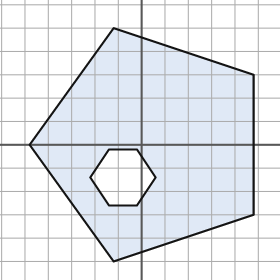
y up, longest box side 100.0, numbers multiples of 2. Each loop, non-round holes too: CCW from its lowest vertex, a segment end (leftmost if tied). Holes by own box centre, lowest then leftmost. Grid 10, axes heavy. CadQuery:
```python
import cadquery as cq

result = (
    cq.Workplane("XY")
    .moveTo(-12.0, -50.0)
    .lineTo(48.0, -30.0)
    .lineTo(48.0, 30.0)
    .lineTo(-12.0, 50.0)
    .lineTo(-48.0, 0.0)
    .close()
    .moveTo(-14.0, -26.0)
    .lineTo(-2.0, -26.0)
    .lineTo(6.0, -14.0)
    .lineTo(-2.0, -2.0)
    .lineTo(-14.0, -2.0)
    .lineTo(-22.0, -14.0)
    .close()
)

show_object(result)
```